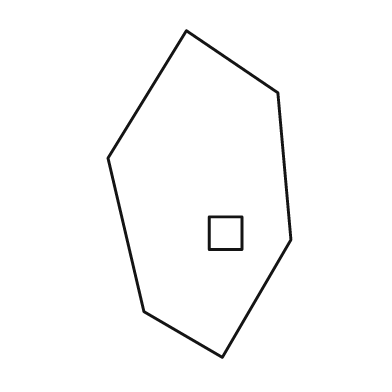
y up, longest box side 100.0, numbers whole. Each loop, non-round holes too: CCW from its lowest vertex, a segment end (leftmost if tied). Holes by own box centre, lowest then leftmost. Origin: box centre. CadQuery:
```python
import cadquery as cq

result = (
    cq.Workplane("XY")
    .moveTo(7.0, -50.0)
    .lineTo(28.0, -14.0)
    .lineTo(24.0, 31.0)
    .lineTo(-4.0, 50.0)
    .lineTo(-28.0, 11.0)
    .lineTo(-17.0, -36.0)
    .close()
    .moveTo(3.0, -17.0)
    .lineTo(13.0, -17.0)
    .lineTo(13.0, -7.0)
    .lineTo(3.0, -7.0)
    .close()
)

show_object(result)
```